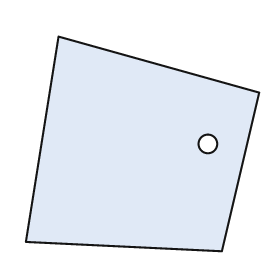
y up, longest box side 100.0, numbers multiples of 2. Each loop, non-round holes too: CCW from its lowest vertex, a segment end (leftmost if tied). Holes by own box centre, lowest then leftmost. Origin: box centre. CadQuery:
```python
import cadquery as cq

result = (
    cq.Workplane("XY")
    .moveTo(34.0, -46.0)
    .lineTo(50.0, 22.0)
    .lineTo(-36.0, 46.0)
    .lineTo(-50.0, -42.0)
    .close()
    .moveTo(28.0, 0.0)
    .circle(4.0)
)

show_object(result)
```